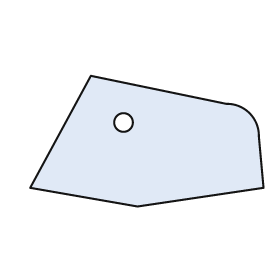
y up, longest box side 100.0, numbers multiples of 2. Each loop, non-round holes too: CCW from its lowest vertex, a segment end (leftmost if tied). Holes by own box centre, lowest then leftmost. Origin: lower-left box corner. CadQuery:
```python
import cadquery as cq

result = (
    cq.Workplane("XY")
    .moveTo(46.0, 0.0)
    .lineTo(100.0, 8.0)
    .lineTo(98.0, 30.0)
    .threePointArc((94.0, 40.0), (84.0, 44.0))
    .lineTo(26.0, 56.0)
    .lineTo(0.0, 8.0)
    .close()
    .moveTo(40.0, 36.0)
    .circle(4.0)
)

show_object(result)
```